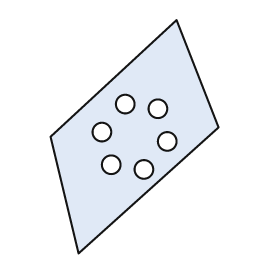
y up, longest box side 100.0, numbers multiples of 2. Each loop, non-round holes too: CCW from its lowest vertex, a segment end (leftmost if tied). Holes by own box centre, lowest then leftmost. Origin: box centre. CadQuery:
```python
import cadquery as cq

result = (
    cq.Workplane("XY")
    .moveTo(-24.0, -50.0)
    .lineTo(36.0, 4.0)
    .lineTo(18.0, 50.0)
    .lineTo(-36.0, 0.0)
    .close()
    .moveTo(4.0, -14.0)
    .circle(4.0)
    .moveTo(-10.0, -12.0)
    .circle(4.0)
    .moveTo(14.0, -2.0)
    .circle(4.0)
    .moveTo(-14.0, 2.0)
    .circle(4.0)
    .moveTo(10.0, 12.0)
    .circle(4.0)
    .moveTo(-4.0, 14.0)
    .circle(4.0)
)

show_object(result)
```